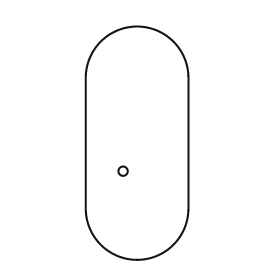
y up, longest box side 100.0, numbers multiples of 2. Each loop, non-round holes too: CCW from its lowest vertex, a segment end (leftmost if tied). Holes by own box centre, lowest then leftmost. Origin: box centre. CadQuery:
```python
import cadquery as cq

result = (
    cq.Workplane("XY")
    .moveTo(-22.0, -28.0)
    .threePointArc((0.0, -50.0), (22.0, -28.0))
    .lineTo(22.0, 28.0)
    .threePointArc((0.0, 50.0), (-22.0, 28.0))
    .close()
    .moveTo(-6.0, -12.0)
    .circle(2.0)
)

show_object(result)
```